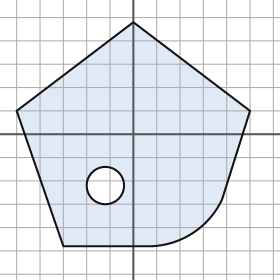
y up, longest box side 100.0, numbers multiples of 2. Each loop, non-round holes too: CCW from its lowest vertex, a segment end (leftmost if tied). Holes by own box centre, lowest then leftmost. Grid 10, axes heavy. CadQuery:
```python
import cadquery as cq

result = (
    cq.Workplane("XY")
    .moveTo(-30.0, -48.0)
    .lineTo(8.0, -48.0)
    .threePointArc((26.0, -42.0), (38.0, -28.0))
    .lineTo(50.0, 10.0)
    .lineTo(0.0, 48.0)
    .lineTo(-50.0, 10.0)
    .close()
    .moveTo(-12.0, -22.0)
    .circle(8.0)
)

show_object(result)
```